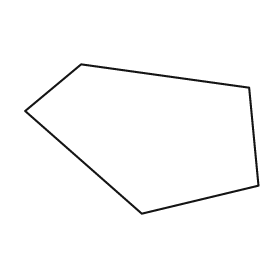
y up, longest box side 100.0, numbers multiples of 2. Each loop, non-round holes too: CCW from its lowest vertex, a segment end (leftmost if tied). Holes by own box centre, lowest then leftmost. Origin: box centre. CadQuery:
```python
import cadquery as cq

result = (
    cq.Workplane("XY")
    .moveTo(0.0, -32.0)
    .lineTo(50.0, -20.0)
    .lineTo(46.0, 22.0)
    .lineTo(-26.0, 32.0)
    .lineTo(-50.0, 12.0)
    .close()
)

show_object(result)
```